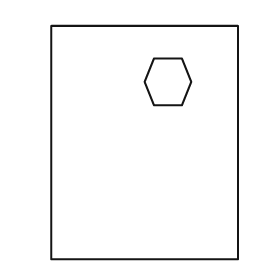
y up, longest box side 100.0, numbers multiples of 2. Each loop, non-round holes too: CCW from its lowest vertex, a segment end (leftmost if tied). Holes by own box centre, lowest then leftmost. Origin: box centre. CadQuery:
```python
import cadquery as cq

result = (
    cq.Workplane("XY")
    .moveTo(-40.0, -50.0)
    .lineTo(40.0, -50.0)
    .lineTo(40.0, 50.0)
    .lineTo(-40.0, 50.0)
    .close()
    .moveTo(4.0, 16.0)
    .lineTo(16.0, 16.0)
    .lineTo(20.0, 26.0)
    .lineTo(16.0, 36.0)
    .lineTo(4.0, 36.0)
    .lineTo(0.0, 26.0)
    .close()
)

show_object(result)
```